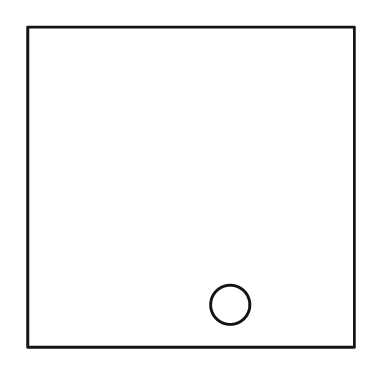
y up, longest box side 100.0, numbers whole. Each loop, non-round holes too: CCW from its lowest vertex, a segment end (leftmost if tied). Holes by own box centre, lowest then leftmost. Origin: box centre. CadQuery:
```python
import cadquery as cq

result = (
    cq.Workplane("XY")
    .moveTo(-50.0, -49.0)
    .lineTo(50.0, -49.0)
    .lineTo(50.0, 49.0)
    .lineTo(-50.0, 49.0)
    .close()
    .moveTo(12.0, -36.0)
    .circle(6.0)
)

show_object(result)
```